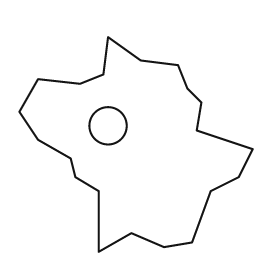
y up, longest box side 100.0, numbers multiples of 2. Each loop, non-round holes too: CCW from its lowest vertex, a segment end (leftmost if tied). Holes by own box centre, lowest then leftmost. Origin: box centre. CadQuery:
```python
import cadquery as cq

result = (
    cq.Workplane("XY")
    .moveTo(-16.0, -46.0)
    .lineTo(-2.0, -38.0)
    .lineTo(12.0, -44.0)
    .lineTo(24.0, -42.0)
    .lineTo(32.0, -20.0)
    .lineTo(44.0, -14.0)
    .lineTo(50.0, -2.0)
    .lineTo(26.0, 6.0)
    .lineTo(28.0, 18.0)
    .lineTo(22.0, 24.0)
    .lineTo(18.0, 34.0)
    .lineTo(2.0, 36.0)
    .lineTo(-12.0, 46.0)
    .lineTo(-14.0, 30.0)
    .lineTo(-24.0, 26.0)
    .lineTo(-42.0, 28.0)
    .lineTo(-50.0, 14.0)
    .lineTo(-42.0, 2.0)
    .lineTo(-28.0, -6.0)
    .lineTo(-26.0, -14.0)
    .lineTo(-16.0, -20.0)
    .close()
    .moveTo(-12.0, 8.0)
    .circle(8.0)
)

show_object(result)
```